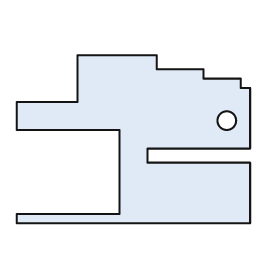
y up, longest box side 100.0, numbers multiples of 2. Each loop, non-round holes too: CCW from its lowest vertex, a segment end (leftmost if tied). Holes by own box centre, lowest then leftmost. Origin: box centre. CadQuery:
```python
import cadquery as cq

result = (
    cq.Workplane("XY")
    .moveTo(-50.0, -36.0)
    .lineTo(50.0, -36.0)
    .lineTo(50.0, -10.0)
    .lineTo(6.0, -10.0)
    .lineTo(6.0, -4.0)
    .lineTo(50.0, -4.0)
    .lineTo(50.0, 22.0)
    .lineTo(46.0, 22.0)
    .lineTo(46.0, 26.0)
    .lineTo(30.0, 26.0)
    .lineTo(30.0, 30.0)
    .lineTo(10.0, 30.0)
    .lineTo(10.0, 36.0)
    .lineTo(-24.0, 36.0)
    .lineTo(-24.0, 16.0)
    .lineTo(-50.0, 16.0)
    .lineTo(-50.0, 4.0)
    .lineTo(-6.0, 4.0)
    .lineTo(-6.0, -32.0)
    .lineTo(-50.0, -32.0)
    .close()
    .moveTo(40.0, 8.0)
    .circle(4.0)
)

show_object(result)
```